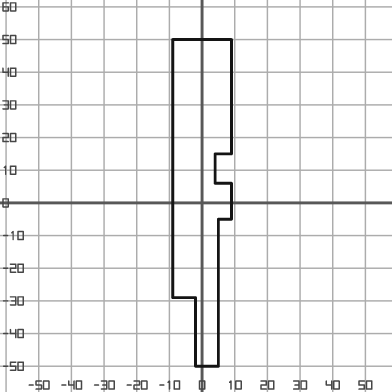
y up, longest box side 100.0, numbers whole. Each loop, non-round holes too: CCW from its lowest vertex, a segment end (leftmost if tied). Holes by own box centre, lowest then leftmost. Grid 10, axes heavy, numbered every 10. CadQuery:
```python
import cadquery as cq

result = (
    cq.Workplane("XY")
    .moveTo(-2.0, -50.0)
    .lineTo(5.0, -50.0)
    .lineTo(5.0, -5.0)
    .lineTo(9.0, -5.0)
    .lineTo(9.0, 6.0)
    .lineTo(4.0, 6.0)
    .lineTo(4.0, 15.0)
    .lineTo(9.0, 15.0)
    .lineTo(9.0, 50.0)
    .lineTo(-9.0, 50.0)
    .lineTo(-9.0, -29.0)
    .lineTo(-2.0, -29.0)
    .close()
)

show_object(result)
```